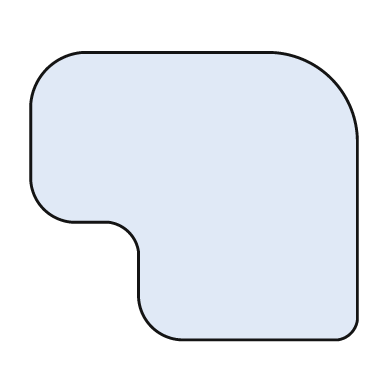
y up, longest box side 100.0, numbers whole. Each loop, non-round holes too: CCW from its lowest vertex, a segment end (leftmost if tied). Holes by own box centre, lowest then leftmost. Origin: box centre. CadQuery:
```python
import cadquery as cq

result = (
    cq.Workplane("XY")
    .moveTo(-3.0, -44.0)
    .lineTo(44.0, -44.0)
    .threePointArc((48.0, -42.0), (50.0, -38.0))
    .lineTo(50.0, 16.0)
    .threePointArc((42.0, 36.0), (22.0, 44.0))
    .lineTo(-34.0, 44.0)
    .threePointArc((-45.0, 39.0), (-50.0, 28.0))
    .lineTo(-50.0, 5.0)
    .threePointArc((-46.0, -4.0), (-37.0, -8.0))
    .lineTo(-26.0, -8.0)
    .threePointArc((-20.0, -11.0), (-17.0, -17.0))
    .lineTo(-17.0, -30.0)
    .threePointArc((-13.0, -40.0), (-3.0, -44.0))
    .close()
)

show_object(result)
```